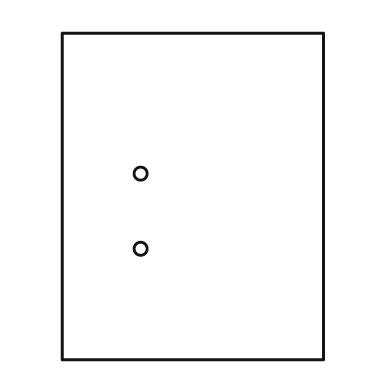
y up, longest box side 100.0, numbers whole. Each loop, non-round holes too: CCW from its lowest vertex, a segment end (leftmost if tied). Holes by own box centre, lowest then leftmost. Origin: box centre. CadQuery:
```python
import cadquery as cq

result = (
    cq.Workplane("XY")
    .moveTo(-40.0, -50.0)
    .lineTo(40.0, -50.0)
    .lineTo(40.0, 50.0)
    .lineTo(-40.0, 50.0)
    .close()
    .moveTo(-16.0, -16.0)
    .circle(2.0)
    .moveTo(-16.0, 7.0)
    .circle(2.0)
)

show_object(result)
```